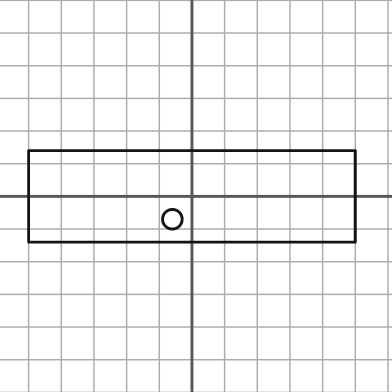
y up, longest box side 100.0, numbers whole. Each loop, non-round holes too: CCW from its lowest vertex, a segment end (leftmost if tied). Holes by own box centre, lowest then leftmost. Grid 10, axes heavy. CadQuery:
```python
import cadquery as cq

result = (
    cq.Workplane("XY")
    .moveTo(-50.0, -14.0)
    .lineTo(50.0, -14.0)
    .lineTo(50.0, 14.0)
    .lineTo(-50.0, 14.0)
    .close()
    .moveTo(-6.0, -7.0)
    .circle(3.0)
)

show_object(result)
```